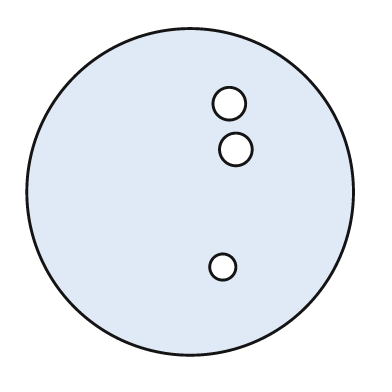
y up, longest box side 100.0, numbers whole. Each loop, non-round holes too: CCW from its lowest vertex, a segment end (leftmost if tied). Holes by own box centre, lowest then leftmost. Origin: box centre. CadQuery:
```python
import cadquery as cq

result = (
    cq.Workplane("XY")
    .moveTo(0.0, 0.0)
    .circle(50.0)
    .moveTo(10.0, -23.0)
    .circle(4.0)
    .moveTo(14.0, 13.0)
    .circle(5.0)
    .moveTo(12.0, 27.0)
    .circle(5.0)
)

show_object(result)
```